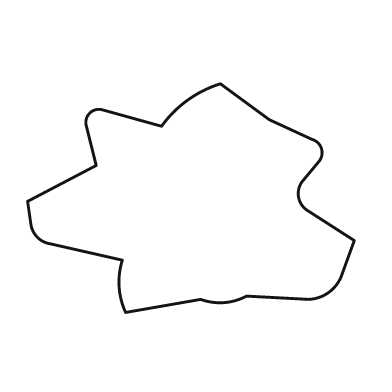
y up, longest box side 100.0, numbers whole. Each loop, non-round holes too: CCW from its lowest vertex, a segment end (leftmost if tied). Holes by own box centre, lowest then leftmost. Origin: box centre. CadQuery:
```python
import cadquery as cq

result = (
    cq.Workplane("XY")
    .moveTo(-20.0, -35.0)
    .lineTo(3.0, -31.0)
    .threePointArc((10.0, -32.0), (17.0, -30.0))
    .lineTo(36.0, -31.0)
    .threePointArc((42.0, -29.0), (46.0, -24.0))
    .lineTo(50.0, -13.0)
    .lineTo(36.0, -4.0)
    .threePointArc((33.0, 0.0), (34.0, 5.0))
    .lineTo(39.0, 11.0)
    .threePointArc((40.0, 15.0), (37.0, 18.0))
    .lineTo(24.0, 24.0)
    .lineTo(9.0, 35.0)
    .threePointArc((-1.0, 30.0), (-9.0, 22.0))
    .lineTo(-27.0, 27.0)
    .threePointArc((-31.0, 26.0), (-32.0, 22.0))
    .lineTo(-29.0, 10.0)
    .lineTo(-50.0, -1.0)
    .lineTo(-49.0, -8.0)
    .threePointArc((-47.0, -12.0), (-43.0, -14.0))
    .lineTo(-21.0, -19.0)
    .threePointArc((-22.0, -27.0), (-20.0, -35.0))
    .close()
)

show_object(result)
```